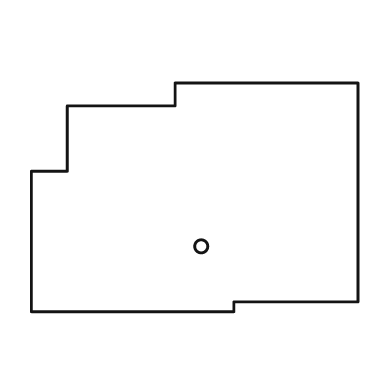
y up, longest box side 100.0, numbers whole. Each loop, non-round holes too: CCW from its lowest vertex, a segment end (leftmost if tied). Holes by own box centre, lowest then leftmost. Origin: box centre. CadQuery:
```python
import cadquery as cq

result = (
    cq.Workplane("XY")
    .moveTo(-50.0, -35.0)
    .lineTo(12.0, -35.0)
    .lineTo(12.0, -32.0)
    .lineTo(50.0, -32.0)
    .lineTo(50.0, 35.0)
    .lineTo(-6.0, 35.0)
    .lineTo(-6.0, 28.0)
    .lineTo(-39.0, 28.0)
    .lineTo(-39.0, 8.0)
    .lineTo(-50.0, 8.0)
    .close()
    .moveTo(2.0, -15.0)
    .circle(2.0)
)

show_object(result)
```